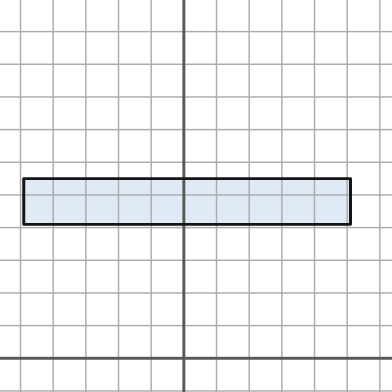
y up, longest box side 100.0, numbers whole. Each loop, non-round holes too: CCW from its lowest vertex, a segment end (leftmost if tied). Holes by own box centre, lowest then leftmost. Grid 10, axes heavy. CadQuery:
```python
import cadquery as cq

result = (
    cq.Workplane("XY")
    .moveTo(-49.0, 41.0)
    .lineTo(51.0, 41.0)
    .lineTo(51.0, 55.0)
    .lineTo(-49.0, 55.0)
    .close()
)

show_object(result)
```